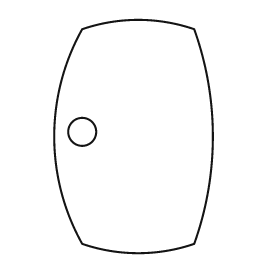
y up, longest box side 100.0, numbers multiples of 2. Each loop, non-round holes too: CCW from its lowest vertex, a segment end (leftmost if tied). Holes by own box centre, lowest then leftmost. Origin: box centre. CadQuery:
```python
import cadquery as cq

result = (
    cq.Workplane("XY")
    .moveTo(-22.0, -46.0)
    .threePointArc((2.0, -50.0), (26.0, -46.0))
    .threePointArc((34.0, 0.0), (26.0, 46.0))
    .threePointArc((2.0, 50.0), (-22.0, 46.0))
    .threePointArc((-34.0, 0.0), (-22.0, -46.0))
    .close()
    .moveTo(-22.0, 2.0)
    .circle(6.0)
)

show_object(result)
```